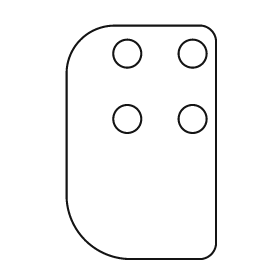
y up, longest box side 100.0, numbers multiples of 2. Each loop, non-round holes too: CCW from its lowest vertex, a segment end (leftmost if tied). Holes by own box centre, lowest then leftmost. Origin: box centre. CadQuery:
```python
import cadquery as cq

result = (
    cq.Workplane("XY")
    .moveTo(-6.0, -50.0)
    .lineTo(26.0, -50.0)
    .threePointArc((30.0, -48.0), (32.0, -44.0))
    .lineTo(32.0, 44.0)
    .threePointArc((30.0, 48.0), (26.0, 50.0))
    .lineTo(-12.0, 50.0)
    .threePointArc((-26.0, 44.0), (-32.0, 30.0))
    .lineTo(-32.0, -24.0)
    .threePointArc((-24.0, -42.0), (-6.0, -50.0))
    .close()
    .moveTo(-6.0, 10.0)
    .circle(6.0)
    .moveTo(22.0, 10.0)
    .circle(6.0)
    .moveTo(-6.0, 38.0)
    .circle(6.0)
    .moveTo(22.0, 38.0)
    .circle(6.0)
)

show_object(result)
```